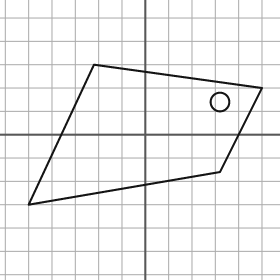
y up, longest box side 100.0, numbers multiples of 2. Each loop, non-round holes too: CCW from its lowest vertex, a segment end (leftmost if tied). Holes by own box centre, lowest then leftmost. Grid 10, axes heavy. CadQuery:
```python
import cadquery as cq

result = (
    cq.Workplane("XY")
    .moveTo(-50.0, -30.0)
    .lineTo(32.0, -16.0)
    .lineTo(50.0, 20.0)
    .lineTo(-22.0, 30.0)
    .close()
    .moveTo(32.0, 14.0)
    .circle(4.0)
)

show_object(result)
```